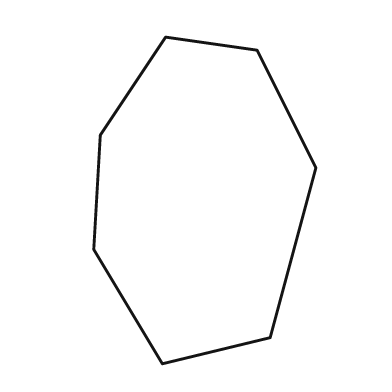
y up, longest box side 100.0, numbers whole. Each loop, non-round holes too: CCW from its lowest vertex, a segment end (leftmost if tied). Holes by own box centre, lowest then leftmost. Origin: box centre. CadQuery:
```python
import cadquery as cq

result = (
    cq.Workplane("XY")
    .moveTo(-13.0, -50.0)
    .lineTo(20.0, -42.0)
    .lineTo(34.0, 10.0)
    .lineTo(16.0, 46.0)
    .lineTo(-12.0, 50.0)
    .lineTo(-32.0, 20.0)
    .lineTo(-34.0, -15.0)
    .close()
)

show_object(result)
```